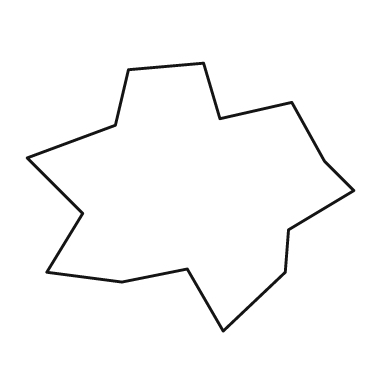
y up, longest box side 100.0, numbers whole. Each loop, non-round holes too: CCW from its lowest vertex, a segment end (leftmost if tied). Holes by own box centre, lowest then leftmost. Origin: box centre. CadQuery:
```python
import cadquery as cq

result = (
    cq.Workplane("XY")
    .moveTo(10.0, -41.0)
    .lineTo(29.0, -23.0)
    .lineTo(30.0, -10.0)
    .lineTo(50.0, 2.0)
    .lineTo(41.0, 11.0)
    .lineTo(31.0, 29.0)
    .lineTo(9.0, 24.0)
    .lineTo(4.0, 41.0)
    .lineTo(-19.0, 39.0)
    .lineTo(-23.0, 22.0)
    .lineTo(-50.0, 12.0)
    .lineTo(-33.0, -5.0)
    .lineTo(-44.0, -23.0)
    .lineTo(-21.0, -26.0)
    .lineTo(-1.0, -22.0)
    .close()
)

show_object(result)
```